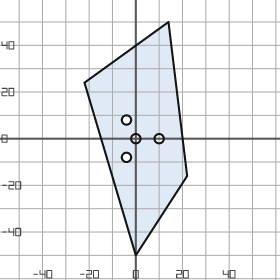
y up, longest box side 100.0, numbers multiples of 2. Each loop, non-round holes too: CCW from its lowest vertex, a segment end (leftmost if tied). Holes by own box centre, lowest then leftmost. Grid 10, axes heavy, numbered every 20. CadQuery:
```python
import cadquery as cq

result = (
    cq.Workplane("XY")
    .moveTo(0.0, -50.0)
    .lineTo(22.0, -16.0)
    .lineTo(14.0, 50.0)
    .lineTo(-22.0, 24.0)
    .close()
    .moveTo(-4.0, -8.0)
    .circle(2.0)
    .moveTo(0.0, 0.0)
    .circle(2.0)
    .moveTo(10.0, 0.0)
    .circle(2.0)
    .moveTo(-4.0, 8.0)
    .circle(2.0)
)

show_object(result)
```